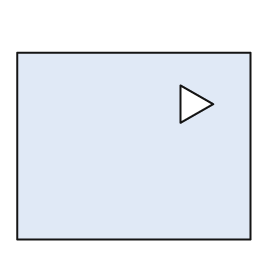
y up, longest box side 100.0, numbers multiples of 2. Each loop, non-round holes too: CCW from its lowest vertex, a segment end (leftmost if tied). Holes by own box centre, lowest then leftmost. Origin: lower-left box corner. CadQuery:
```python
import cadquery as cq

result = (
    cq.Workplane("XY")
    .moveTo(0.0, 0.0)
    .lineTo(100.0, 0.0)
    .lineTo(100.0, 80.0)
    .lineTo(0.0, 80.0)
    .close()
    .moveTo(70.0, 50.0)
    .lineTo(84.0, 58.0)
    .lineTo(70.0, 66.0)
    .close()
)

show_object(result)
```